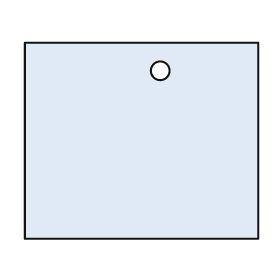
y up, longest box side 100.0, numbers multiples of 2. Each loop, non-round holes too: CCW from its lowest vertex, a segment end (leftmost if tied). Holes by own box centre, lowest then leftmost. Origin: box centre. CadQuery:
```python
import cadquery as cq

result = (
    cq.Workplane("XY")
    .moveTo(-50.0, -42.0)
    .lineTo(50.0, -42.0)
    .lineTo(50.0, 42.0)
    .lineTo(-50.0, 42.0)
    .close()
    .moveTo(8.0, 30.0)
    .circle(4.0)
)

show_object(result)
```